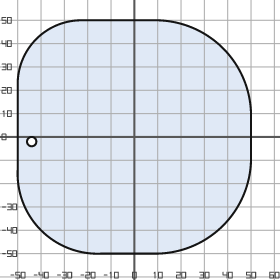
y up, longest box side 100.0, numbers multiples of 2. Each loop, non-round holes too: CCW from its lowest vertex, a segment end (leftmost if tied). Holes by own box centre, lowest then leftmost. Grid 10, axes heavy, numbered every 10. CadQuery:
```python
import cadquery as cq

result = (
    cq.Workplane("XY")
    .moveTo(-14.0, -50.0)
    .lineTo(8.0, -50.0)
    .threePointArc((38.0, -38.0), (50.0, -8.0))
    .lineTo(50.0, 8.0)
    .threePointArc((38.0, 38.0), (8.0, 50.0))
    .lineTo(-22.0, 50.0)
    .threePointArc((-42.0, 42.0), (-50.0, 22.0))
    .lineTo(-50.0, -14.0)
    .threePointArc((-40.0, -40.0), (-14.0, -50.0))
    .close()
    .moveTo(-44.0, -2.0)
    .circle(2.0)
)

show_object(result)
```